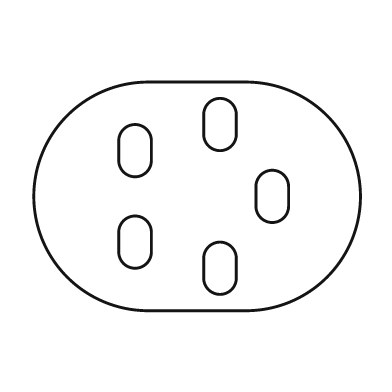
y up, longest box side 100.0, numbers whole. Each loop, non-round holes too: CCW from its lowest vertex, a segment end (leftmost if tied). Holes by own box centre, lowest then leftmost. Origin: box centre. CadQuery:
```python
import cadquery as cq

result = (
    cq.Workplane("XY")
    .moveTo(-15.0, -35.0)
    .lineTo(15.0, -35.0)
    .threePointArc((50.0, 0.0), (15.0, 35.0))
    .lineTo(-15.0, 35.0)
    .threePointArc((-50.0, 0.0), (-15.0, -35.0))
    .close()
    .moveTo(2.0, -25.0)
    .threePointArc((7.0, -30.0), (12.0, -25.0))
    .lineTo(12.0, -19.0)
    .threePointArc((7.0, -14.0), (2.0, -19.0))
    .close()
    .moveTo(-24.0, -17.0)
    .threePointArc((-19.0, -22.0), (-14.0, -17.0))
    .lineTo(-14.0, -11.0)
    .threePointArc((-19.0, -6.0), (-24.0, -11.0))
    .close()
    .moveTo(18.0, -3.0)
    .threePointArc((23.0, -8.0), (28.0, -3.0))
    .lineTo(28.0, 3.0)
    .threePointArc((23.0, 8.0), (18.0, 3.0))
    .close()
    .moveTo(-24.0, 11.0)
    .threePointArc((-19.0, 6.0), (-14.0, 11.0))
    .lineTo(-14.0, 17.0)
    .threePointArc((-19.0, 22.0), (-24.0, 17.0))
    .close()
    .moveTo(2.0, 19.0)
    .threePointArc((7.0, 14.0), (12.0, 19.0))
    .lineTo(12.0, 25.0)
    .threePointArc((7.0, 30.0), (2.0, 25.0))
    .close()
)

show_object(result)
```